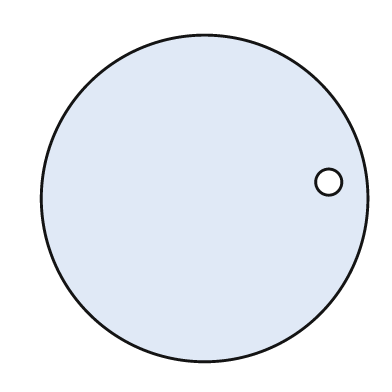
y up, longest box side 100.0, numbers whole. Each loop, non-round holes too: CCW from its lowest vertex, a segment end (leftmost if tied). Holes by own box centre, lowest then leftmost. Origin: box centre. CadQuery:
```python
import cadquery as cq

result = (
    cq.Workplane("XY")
    .moveTo(0.0, 0.0)
    .circle(50.0)
    .moveTo(38.0, 5.0)
    .circle(4.0)
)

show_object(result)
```